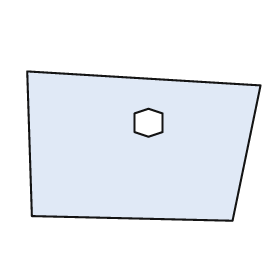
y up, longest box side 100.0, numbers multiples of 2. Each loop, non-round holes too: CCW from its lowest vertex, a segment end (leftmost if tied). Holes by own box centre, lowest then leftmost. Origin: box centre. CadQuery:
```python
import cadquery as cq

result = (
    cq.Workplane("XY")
    .moveTo(38.0, -32.0)
    .lineTo(50.0, 26.0)
    .lineTo(-50.0, 32.0)
    .lineTo(-48.0, -30.0)
    .close()
    .moveTo(2.0, 4.0)
    .lineTo(8.0, 6.0)
    .lineTo(8.0, 14.0)
    .lineTo(2.0, 16.0)
    .lineTo(-4.0, 14.0)
    .lineTo(-4.0, 6.0)
    .close()
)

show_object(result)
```